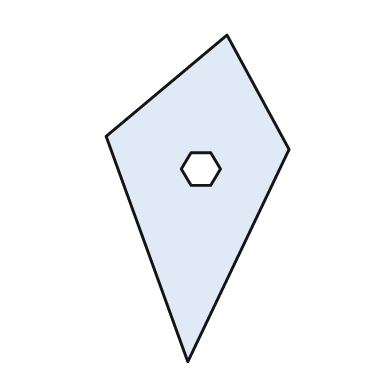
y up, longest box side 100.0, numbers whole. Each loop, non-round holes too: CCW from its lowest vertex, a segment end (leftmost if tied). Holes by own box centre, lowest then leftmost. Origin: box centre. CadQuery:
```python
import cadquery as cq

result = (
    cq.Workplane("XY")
    .moveTo(-3.0, -50.0)
    .lineTo(28.0, 15.0)
    .lineTo(9.0, 50.0)
    .lineTo(-28.0, 19.0)
    .close()
    .moveTo(-2.0, 4.0)
    .lineTo(4.0, 4.0)
    .lineTo(7.0, 9.0)
    .lineTo(4.0, 14.0)
    .lineTo(-2.0, 14.0)
    .lineTo(-5.0, 9.0)
    .close()
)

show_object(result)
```